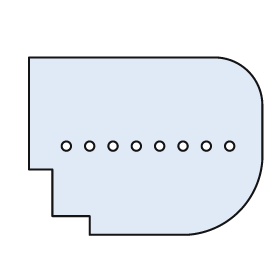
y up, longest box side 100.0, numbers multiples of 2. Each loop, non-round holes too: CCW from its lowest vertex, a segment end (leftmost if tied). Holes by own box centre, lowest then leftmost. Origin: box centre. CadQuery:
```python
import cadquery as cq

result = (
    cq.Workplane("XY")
    .moveTo(-24.0, -38.0)
    .lineTo(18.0, -38.0)
    .threePointArc((40.0, -28.0), (50.0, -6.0))
    .lineTo(50.0, 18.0)
    .threePointArc((44.0, 32.0), (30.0, 38.0))
    .lineTo(-50.0, 38.0)
    .lineTo(-50.0, -10.0)
    .lineTo(-40.0, -10.0)
    .lineTo(-40.0, -30.0)
    .lineTo(-24.0, -30.0)
    .close()
    .moveTo(-34.0, 0.0)
    .circle(2.0)
    .moveTo(-24.0, 0.0)
    .circle(2.0)
    .moveTo(-14.0, 0.0)
    .circle(2.0)
    .moveTo(-4.0, 0.0)
    .circle(2.0)
    .moveTo(6.0, 0.0)
    .circle(2.0)
    .moveTo(16.0, 0.0)
    .circle(2.0)
    .moveTo(26.0, 0.0)
    .circle(2.0)
    .moveTo(36.0, 0.0)
    .circle(2.0)
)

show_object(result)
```